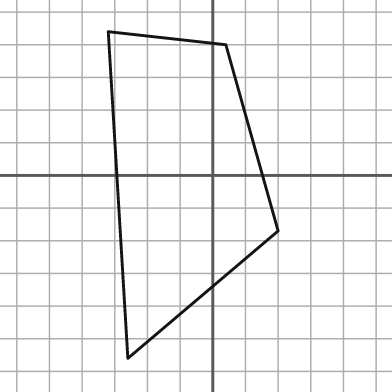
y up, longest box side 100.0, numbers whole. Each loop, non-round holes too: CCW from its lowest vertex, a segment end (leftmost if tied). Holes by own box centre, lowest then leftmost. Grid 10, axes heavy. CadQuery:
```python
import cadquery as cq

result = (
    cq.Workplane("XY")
    .moveTo(-26.0, -56.0)
    .lineTo(20.0, -17.0)
    .lineTo(4.0, 40.0)
    .lineTo(-32.0, 44.0)
    .close()
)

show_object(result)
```